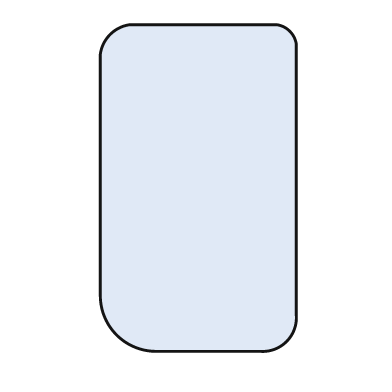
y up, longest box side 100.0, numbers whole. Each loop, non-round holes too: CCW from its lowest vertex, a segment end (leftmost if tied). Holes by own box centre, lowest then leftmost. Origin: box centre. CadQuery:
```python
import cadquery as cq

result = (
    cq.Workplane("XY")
    .moveTo(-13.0, -50.0)
    .lineTo(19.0, -50.0)
    .threePointArc((27.0, -47.0), (30.0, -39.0))
    .lineTo(30.0, 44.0)
    .threePointArc((28.0, 48.0), (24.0, 50.0))
    .lineTo(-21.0, 50.0)
    .threePointArc((-27.0, 47.0), (-30.0, 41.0))
    .lineTo(-30.0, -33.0)
    .threePointArc((-25.0, -45.0), (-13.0, -50.0))
    .close()
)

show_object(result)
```